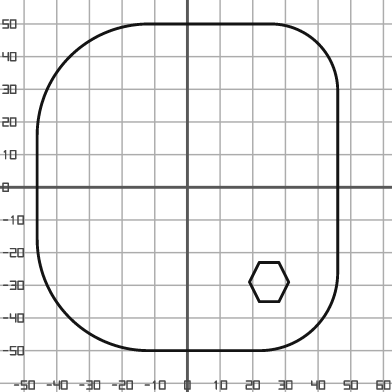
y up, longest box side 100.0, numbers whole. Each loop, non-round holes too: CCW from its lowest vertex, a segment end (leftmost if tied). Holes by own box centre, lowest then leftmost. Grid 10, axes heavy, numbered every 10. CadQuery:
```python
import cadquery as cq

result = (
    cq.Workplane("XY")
    .moveTo(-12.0, -50.0)
    .lineTo(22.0, -50.0)
    .threePointArc((39.0, -43.0), (46.0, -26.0))
    .lineTo(46.0, 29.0)
    .threePointArc((40.0, 44.0), (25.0, 50.0))
    .lineTo(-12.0, 50.0)
    .threePointArc((-36.0, 40.0), (-46.0, 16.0))
    .lineTo(-46.0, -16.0)
    .threePointArc((-36.0, -40.0), (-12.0, -50.0))
    .close()
    .moveTo(22.0, -35.0)
    .lineTo(28.0, -35.0)
    .lineTo(31.0, -29.0)
    .lineTo(28.0, -23.0)
    .lineTo(22.0, -23.0)
    .lineTo(19.0, -29.0)
    .close()
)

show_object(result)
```